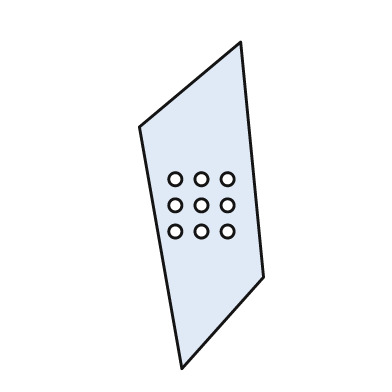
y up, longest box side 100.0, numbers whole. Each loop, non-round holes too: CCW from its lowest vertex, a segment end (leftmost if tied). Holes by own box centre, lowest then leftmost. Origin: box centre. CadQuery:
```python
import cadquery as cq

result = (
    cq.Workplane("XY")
    .moveTo(-6.0, -50.0)
    .lineTo(19.0, -22.0)
    .lineTo(12.0, 50.0)
    .lineTo(-19.0, 24.0)
    .close()
    .moveTo(-8.0, -8.0)
    .circle(2.0)
    .moveTo(0.0, -8.0)
    .circle(2.0)
    .moveTo(8.0, -8.0)
    .circle(2.0)
    .moveTo(-8.0, 0.0)
    .circle(2.0)
    .moveTo(0.0, 0.0)
    .circle(2.0)
    .moveTo(8.0, 0.0)
    .circle(2.0)
    .moveTo(-8.0, 8.0)
    .circle(2.0)
    .moveTo(0.0, 8.0)
    .circle(2.0)
    .moveTo(8.0, 8.0)
    .circle(2.0)
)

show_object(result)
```